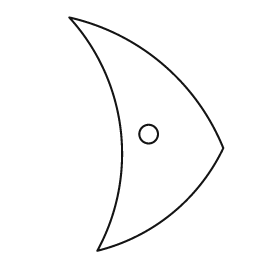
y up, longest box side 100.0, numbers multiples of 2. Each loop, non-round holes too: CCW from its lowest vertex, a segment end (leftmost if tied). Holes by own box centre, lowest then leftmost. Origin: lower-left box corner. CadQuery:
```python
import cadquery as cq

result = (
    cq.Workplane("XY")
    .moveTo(12.0, 0.0)
    .threePointArc((44.0, 16.0), (66.0, 44.0))
    .threePointArc((40.0, 80.0), (0.0, 100.0))
    .threePointArc((22.0, 52.0), (12.0, 0.0))
    .close()
    .moveTo(34.0, 50.0)
    .circle(4.0)
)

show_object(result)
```